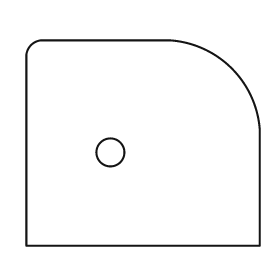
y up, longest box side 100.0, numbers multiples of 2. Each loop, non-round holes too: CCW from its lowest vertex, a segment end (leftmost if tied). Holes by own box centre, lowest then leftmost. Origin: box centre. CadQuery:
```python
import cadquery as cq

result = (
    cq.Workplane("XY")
    .moveTo(-50.0, -44.0)
    .lineTo(50.0, -44.0)
    .lineTo(50.0, 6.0)
    .threePointArc((38.0, 32.0), (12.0, 44.0))
    .lineTo(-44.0, 44.0)
    .threePointArc((-48.0, 42.0), (-50.0, 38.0))
    .close()
    .moveTo(-14.0, -4.0)
    .circle(6.0)
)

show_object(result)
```